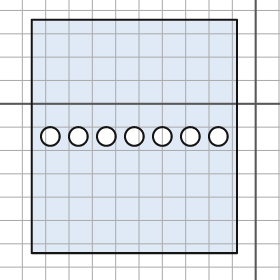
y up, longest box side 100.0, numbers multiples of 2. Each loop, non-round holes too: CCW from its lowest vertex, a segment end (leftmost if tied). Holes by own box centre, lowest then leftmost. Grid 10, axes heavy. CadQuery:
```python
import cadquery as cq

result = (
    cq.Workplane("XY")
    .moveTo(-96.0, -64.0)
    .lineTo(-8.0, -64.0)
    .lineTo(-8.0, 36.0)
    .lineTo(-96.0, 36.0)
    .close()
    .moveTo(-88.0, -14.0)
    .circle(4.0)
    .moveTo(-76.0, -14.0)
    .circle(4.0)
    .moveTo(-64.0, -14.0)
    .circle(4.0)
    .moveTo(-52.0, -14.0)
    .circle(4.0)
    .moveTo(-40.0, -14.0)
    .circle(4.0)
    .moveTo(-28.0, -14.0)
    .circle(4.0)
    .moveTo(-16.0, -14.0)
    .circle(4.0)
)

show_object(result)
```